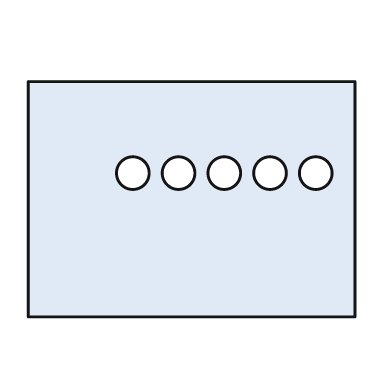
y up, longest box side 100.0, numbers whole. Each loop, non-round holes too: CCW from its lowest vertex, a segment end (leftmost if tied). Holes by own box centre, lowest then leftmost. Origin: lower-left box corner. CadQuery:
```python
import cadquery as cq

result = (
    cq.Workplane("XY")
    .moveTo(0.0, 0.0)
    .lineTo(100.0, 0.0)
    .lineTo(100.0, 72.0)
    .lineTo(0.0, 72.0)
    .close()
    .moveTo(32.0, 44.0)
    .circle(5.0)
    .moveTo(46.0, 44.0)
    .circle(5.0)
    .moveTo(60.0, 44.0)
    .circle(5.0)
    .moveTo(74.0, 44.0)
    .circle(5.0)
    .moveTo(88.0, 44.0)
    .circle(5.0)
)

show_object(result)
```